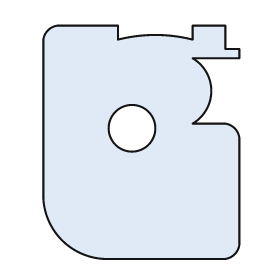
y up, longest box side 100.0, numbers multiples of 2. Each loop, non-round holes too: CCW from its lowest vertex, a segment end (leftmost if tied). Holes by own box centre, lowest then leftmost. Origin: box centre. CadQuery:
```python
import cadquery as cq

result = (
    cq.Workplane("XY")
    .moveTo(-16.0, -50.0)
    .lineTo(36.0, -50.0)
    .threePointArc((40.0, -48.0), (42.0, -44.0))
    .lineTo(42.0, 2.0)
    .threePointArc((40.0, 6.0), (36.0, 8.0))
    .lineTo(22.0, 8.0)
    .threePointArc((30.0, 22.0), (22.0, 36.0))
    .lineTo(42.0, 36.0)
    .lineTo(42.0, 40.0)
    .lineTo(36.0, 40.0)
    .lineTo(36.0, 50.0)
    .lineTo(22.0, 50.0)
    .lineTo(22.0, 44.0)
    .threePointArc((6.0, 46.0), (-10.0, 44.0))
    .lineTo(-10.0, 50.0)
    .lineTo(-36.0, 50.0)
    .threePointArc((-40.0, 48.0), (-42.0, 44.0))
    .lineTo(-42.0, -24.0)
    .threePointArc((-34.0, -42.0), (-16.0, -50.0))
    .close()
    .moveTo(-4.0, 6.0)
    .circle(10.0)
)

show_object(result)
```